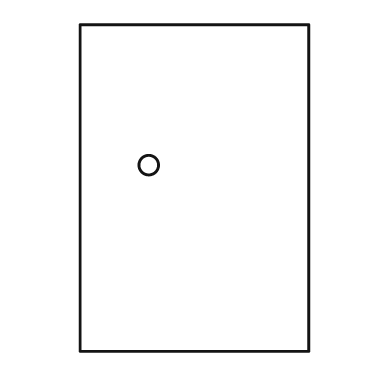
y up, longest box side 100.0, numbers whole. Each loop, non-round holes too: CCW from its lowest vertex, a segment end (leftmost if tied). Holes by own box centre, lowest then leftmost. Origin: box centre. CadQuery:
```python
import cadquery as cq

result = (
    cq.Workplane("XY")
    .moveTo(-35.0, -50.0)
    .lineTo(35.0, -50.0)
    .lineTo(35.0, 50.0)
    .lineTo(-35.0, 50.0)
    .close()
    .moveTo(-14.0, 7.0)
    .circle(3.0)
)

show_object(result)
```